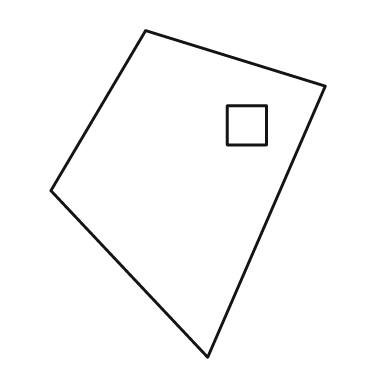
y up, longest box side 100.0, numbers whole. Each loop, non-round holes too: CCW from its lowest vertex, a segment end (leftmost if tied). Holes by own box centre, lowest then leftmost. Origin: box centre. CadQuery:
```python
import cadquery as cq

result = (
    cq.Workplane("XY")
    .moveTo(6.0, -50.0)
    .lineTo(42.0, 33.0)
    .lineTo(-13.0, 50.0)
    .lineTo(-42.0, 1.0)
    .close()
    .moveTo(12.0, 15.0)
    .lineTo(24.0, 15.0)
    .lineTo(24.0, 27.0)
    .lineTo(12.0, 27.0)
    .close()
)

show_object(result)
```